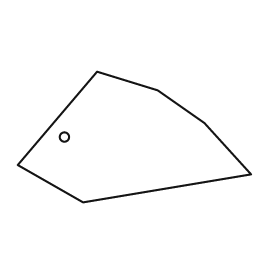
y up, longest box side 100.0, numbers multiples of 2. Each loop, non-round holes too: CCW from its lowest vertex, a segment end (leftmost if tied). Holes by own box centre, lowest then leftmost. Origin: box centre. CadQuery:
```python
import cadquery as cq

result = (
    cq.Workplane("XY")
    .moveTo(-22.0, -28.0)
    .lineTo(50.0, -16.0)
    .lineTo(30.0, 6.0)
    .lineTo(10.0, 20.0)
    .lineTo(-16.0, 28.0)
    .lineTo(-50.0, -12.0)
    .close()
    .moveTo(-30.0, 0.0)
    .circle(2.0)
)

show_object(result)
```